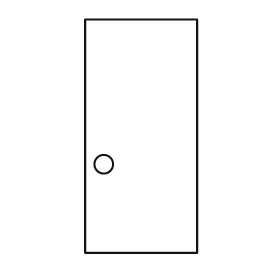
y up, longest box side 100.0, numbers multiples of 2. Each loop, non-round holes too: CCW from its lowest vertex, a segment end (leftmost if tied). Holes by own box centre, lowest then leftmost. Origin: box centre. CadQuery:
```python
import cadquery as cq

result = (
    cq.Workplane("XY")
    .moveTo(-24.0, -50.0)
    .lineTo(24.0, -50.0)
    .lineTo(24.0, 50.0)
    .lineTo(-24.0, 50.0)
    .close()
    .moveTo(-16.0, -12.0)
    .circle(4.0)
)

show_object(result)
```